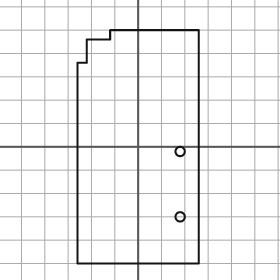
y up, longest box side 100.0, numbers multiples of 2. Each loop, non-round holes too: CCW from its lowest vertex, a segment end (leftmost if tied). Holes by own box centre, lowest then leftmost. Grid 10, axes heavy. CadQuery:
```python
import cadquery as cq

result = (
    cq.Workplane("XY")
    .moveTo(-26.0, -50.0)
    .lineTo(26.0, -50.0)
    .lineTo(26.0, 50.0)
    .lineTo(-12.0, 50.0)
    .lineTo(-12.0, 46.0)
    .lineTo(-22.0, 46.0)
    .lineTo(-22.0, 36.0)
    .lineTo(-26.0, 36.0)
    .close()
    .moveTo(18.0, -30.0)
    .circle(2.0)
    .moveTo(18.0, -2.0)
    .circle(2.0)
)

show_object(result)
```